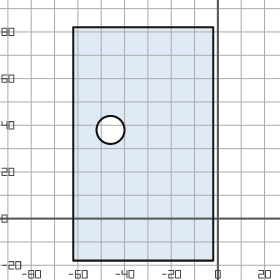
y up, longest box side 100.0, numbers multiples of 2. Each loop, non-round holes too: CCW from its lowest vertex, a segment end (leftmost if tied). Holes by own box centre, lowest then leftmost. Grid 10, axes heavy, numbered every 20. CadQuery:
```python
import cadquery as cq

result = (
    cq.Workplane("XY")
    .moveTo(-62.0, -18.0)
    .lineTo(-2.0, -18.0)
    .lineTo(-2.0, 82.0)
    .lineTo(-62.0, 82.0)
    .close()
    .moveTo(-46.0, 38.0)
    .circle(6.0)
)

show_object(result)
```